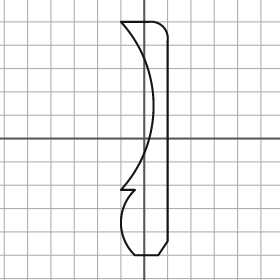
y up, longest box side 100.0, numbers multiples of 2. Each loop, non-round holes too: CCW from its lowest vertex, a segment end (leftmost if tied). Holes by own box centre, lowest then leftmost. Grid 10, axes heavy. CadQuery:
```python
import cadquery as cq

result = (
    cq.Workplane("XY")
    .moveTo(-4.0, -50.0)
    .lineTo(6.0, -50.0)
    .lineTo(10.0, -44.0)
    .lineTo(10.0, 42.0)
    .threePointArc((8.0, 48.0), (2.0, 50.0))
    .lineTo(-10.0, 50.0)
    .threePointArc((4.0, 14.0), (-10.0, -22.0))
    .lineTo(-4.0, -22.0)
    .threePointArc((-10.0, -36.0), (-4.0, -50.0))
    .close()
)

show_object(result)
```